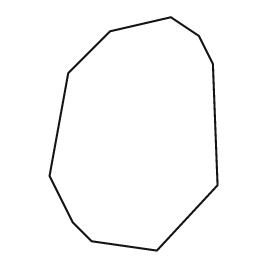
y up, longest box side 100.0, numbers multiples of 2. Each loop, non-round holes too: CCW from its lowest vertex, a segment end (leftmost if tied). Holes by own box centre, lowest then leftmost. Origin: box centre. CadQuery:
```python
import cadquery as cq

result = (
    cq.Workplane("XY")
    .moveTo(10.0, -50.0)
    .lineTo(36.0, -22.0)
    .lineTo(34.0, 30.0)
    .lineTo(28.0, 42.0)
    .lineTo(16.0, 50.0)
    .lineTo(-10.0, 44.0)
    .lineTo(-28.0, 26.0)
    .lineTo(-36.0, -18.0)
    .lineTo(-26.0, -38.0)
    .lineTo(-18.0, -46.0)
    .close()
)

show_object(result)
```